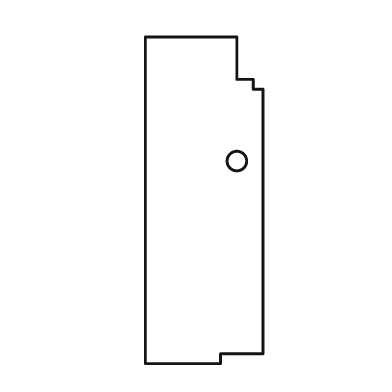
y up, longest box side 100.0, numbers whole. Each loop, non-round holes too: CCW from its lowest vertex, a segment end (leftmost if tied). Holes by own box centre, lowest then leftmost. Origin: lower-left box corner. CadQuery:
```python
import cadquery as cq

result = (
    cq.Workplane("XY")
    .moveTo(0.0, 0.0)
    .lineTo(23.0, 0.0)
    .lineTo(23.0, 3.0)
    .lineTo(36.0, 3.0)
    .lineTo(36.0, 84.0)
    .lineTo(33.0, 84.0)
    .lineTo(33.0, 87.0)
    .lineTo(28.0, 87.0)
    .lineTo(28.0, 100.0)
    .lineTo(0.0, 100.0)
    .close()
    .moveTo(28.0, 62.0)
    .circle(3.0)
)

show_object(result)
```